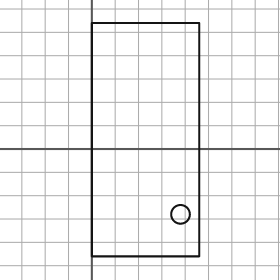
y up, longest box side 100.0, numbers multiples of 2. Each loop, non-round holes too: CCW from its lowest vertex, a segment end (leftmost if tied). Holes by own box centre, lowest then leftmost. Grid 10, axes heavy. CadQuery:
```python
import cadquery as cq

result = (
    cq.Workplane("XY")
    .moveTo(0.0, -46.0)
    .lineTo(46.0, -46.0)
    .lineTo(46.0, 54.0)
    .lineTo(0.0, 54.0)
    .close()
    .moveTo(38.0, -28.0)
    .circle(4.0)
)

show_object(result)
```